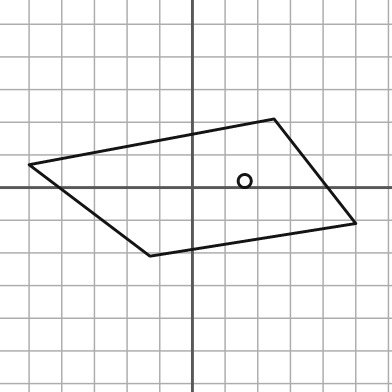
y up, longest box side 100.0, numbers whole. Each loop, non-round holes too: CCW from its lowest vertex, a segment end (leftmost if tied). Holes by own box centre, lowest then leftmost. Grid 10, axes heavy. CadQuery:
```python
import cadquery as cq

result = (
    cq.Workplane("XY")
    .moveTo(-13.0, -21.0)
    .lineTo(50.0, -11.0)
    .lineTo(25.0, 21.0)
    .lineTo(-50.0, 7.0)
    .close()
    .moveTo(16.0, 2.0)
    .circle(2.0)
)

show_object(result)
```